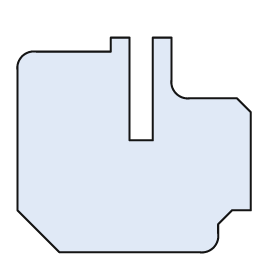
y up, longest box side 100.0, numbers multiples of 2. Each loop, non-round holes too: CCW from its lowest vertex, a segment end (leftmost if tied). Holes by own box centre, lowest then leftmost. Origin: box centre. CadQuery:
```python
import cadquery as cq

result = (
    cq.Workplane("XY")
    .moveTo(-32.0, -46.0)
    .lineTo(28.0, -46.0)
    .threePointArc((34.0, -44.0), (36.0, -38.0))
    .lineTo(36.0, -34.0)
    .lineTo(42.0, -28.0)
    .lineTo(50.0, -28.0)
    .lineTo(50.0, 14.0)
    .lineTo(44.0, 20.0)
    .lineTo(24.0, 20.0)
    .threePointArc((18.0, 22.0), (16.0, 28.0))
    .lineTo(16.0, 46.0)
    .lineTo(8.0, 46.0)
    .lineTo(8.0, 2.0)
    .lineTo(-2.0, 2.0)
    .lineTo(-2.0, 46.0)
    .lineTo(-10.0, 46.0)
    .lineTo(-10.0, 40.0)
    .lineTo(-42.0, 40.0)
    .threePointArc((-48.0, 38.0), (-50.0, 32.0))
    .lineTo(-50.0, -28.0)
    .close()
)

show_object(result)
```